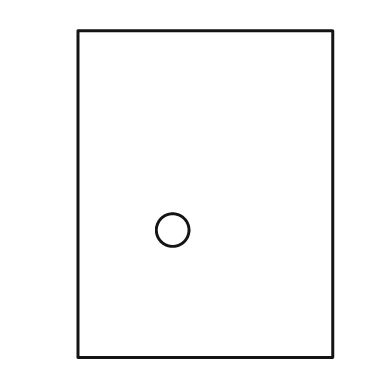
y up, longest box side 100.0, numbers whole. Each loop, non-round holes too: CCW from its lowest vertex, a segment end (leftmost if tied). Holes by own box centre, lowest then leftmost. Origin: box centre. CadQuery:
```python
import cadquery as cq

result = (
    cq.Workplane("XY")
    .moveTo(-39.0, -50.0)
    .lineTo(39.0, -50.0)
    .lineTo(39.0, 50.0)
    .lineTo(-39.0, 50.0)
    .close()
    .moveTo(-10.0, -11.0)
    .circle(5.0)
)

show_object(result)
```